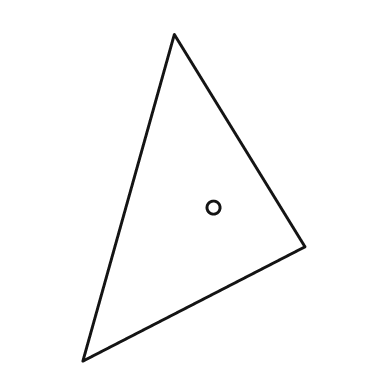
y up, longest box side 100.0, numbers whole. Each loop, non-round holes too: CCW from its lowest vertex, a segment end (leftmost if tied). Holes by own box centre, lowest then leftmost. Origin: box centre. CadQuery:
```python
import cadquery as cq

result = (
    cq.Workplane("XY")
    .moveTo(-34.0, -50.0)
    .lineTo(34.0, -15.0)
    .lineTo(-6.0, 50.0)
    .close()
    .moveTo(6.0, -3.0)
    .circle(2.0)
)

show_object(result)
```